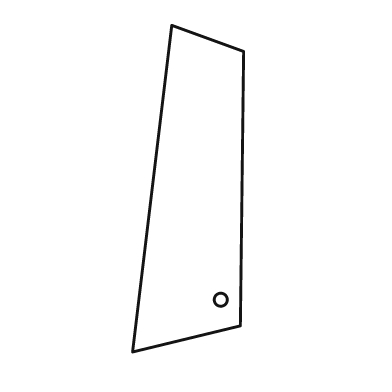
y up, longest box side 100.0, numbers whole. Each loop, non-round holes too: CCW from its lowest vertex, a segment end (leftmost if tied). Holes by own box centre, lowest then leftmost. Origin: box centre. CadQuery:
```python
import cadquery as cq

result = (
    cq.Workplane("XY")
    .moveTo(-17.0, -50.0)
    .lineTo(16.0, -42.0)
    .lineTo(17.0, 42.0)
    .lineTo(-5.0, 50.0)
    .close()
    .moveTo(10.0, -34.0)
    .circle(2.0)
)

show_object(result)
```